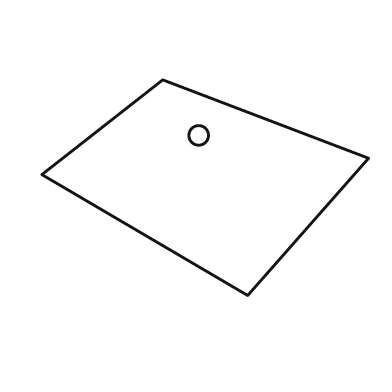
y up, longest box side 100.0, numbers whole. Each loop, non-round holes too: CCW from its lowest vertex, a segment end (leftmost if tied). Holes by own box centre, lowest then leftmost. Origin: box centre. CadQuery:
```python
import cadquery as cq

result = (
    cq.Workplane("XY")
    .moveTo(13.0, -33.0)
    .lineTo(50.0, 9.0)
    .lineTo(-13.0, 33.0)
    .lineTo(-50.0, 4.0)
    .close()
    .moveTo(-2.0, 16.0)
    .circle(3.0)
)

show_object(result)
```